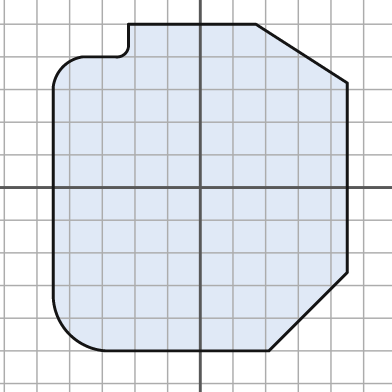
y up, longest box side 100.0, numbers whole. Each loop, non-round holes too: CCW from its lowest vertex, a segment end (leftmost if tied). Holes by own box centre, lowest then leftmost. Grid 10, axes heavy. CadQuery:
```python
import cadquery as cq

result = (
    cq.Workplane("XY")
    .moveTo(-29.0, -50.0)
    .lineTo(21.0, -50.0)
    .lineTo(45.0, -26.0)
    .lineTo(45.0, 32.0)
    .lineTo(17.0, 50.0)
    .lineTo(-22.0, 50.0)
    .lineTo(-22.0, 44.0)
    .threePointArc((-23.0, 41.0), (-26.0, 40.0))
    .lineTo(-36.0, 40.0)
    .threePointArc((-42.0, 37.0), (-45.0, 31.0))
    .lineTo(-45.0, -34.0)
    .threePointArc((-40.0, -45.0), (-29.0, -50.0))
    .close()
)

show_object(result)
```